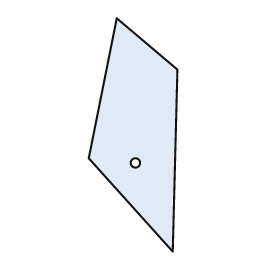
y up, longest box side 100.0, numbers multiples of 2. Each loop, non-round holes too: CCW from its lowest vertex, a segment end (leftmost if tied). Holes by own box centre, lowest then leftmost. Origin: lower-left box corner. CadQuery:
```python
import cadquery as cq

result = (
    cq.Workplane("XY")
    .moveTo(36.0, 0.0)
    .lineTo(38.0, 78.0)
    .lineTo(12.0, 100.0)
    .lineTo(0.0, 40.0)
    .close()
    .moveTo(20.0, 38.0)
    .circle(2.0)
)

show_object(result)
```